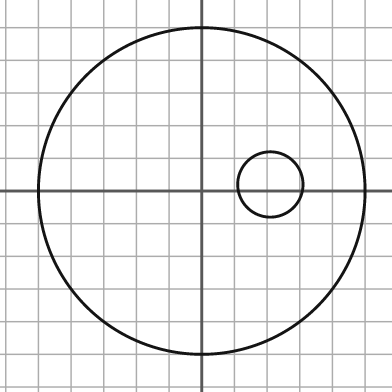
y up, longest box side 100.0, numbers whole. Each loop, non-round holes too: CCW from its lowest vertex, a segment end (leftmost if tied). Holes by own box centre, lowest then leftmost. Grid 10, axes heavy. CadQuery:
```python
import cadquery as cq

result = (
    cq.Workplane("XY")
    .moveTo(0.0, 0.0)
    .circle(50.0)
    .moveTo(21.0, 2.0)
    .circle(10.0)
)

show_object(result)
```